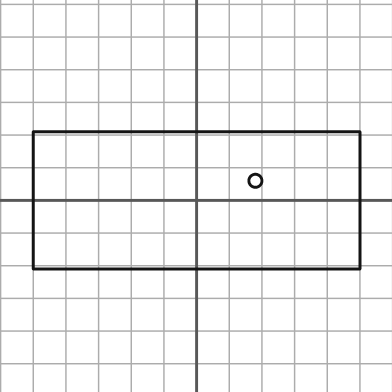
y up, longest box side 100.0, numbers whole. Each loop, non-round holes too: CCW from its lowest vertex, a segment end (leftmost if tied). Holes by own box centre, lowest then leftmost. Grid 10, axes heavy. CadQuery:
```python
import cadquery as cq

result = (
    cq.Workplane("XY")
    .moveTo(-50.0, -21.0)
    .lineTo(50.0, -21.0)
    .lineTo(50.0, 21.0)
    .lineTo(-50.0, 21.0)
    .close()
    .moveTo(18.0, 6.0)
    .circle(2.0)
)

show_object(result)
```